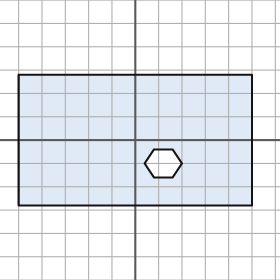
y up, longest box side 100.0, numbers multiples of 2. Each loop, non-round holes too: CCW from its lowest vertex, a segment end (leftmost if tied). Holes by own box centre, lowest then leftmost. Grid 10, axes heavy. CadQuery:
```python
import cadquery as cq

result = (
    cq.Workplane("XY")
    .moveTo(-50.0, -28.0)
    .lineTo(50.0, -28.0)
    .lineTo(50.0, 28.0)
    .lineTo(-50.0, 28.0)
    .close()
    .moveTo(8.0, -16.0)
    .lineTo(16.0, -16.0)
    .lineTo(20.0, -10.0)
    .lineTo(16.0, -4.0)
    .lineTo(8.0, -4.0)
    .lineTo(4.0, -10.0)
    .close()
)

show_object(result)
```